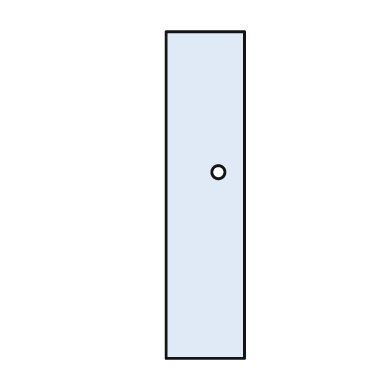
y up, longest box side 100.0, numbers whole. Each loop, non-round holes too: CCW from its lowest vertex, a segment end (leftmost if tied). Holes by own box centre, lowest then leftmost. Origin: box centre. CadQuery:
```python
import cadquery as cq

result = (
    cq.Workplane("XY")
    .moveTo(-12.0, -50.0)
    .lineTo(12.0, -50.0)
    .lineTo(12.0, 50.0)
    .lineTo(-12.0, 50.0)
    .close()
    .moveTo(4.0, 7.0)
    .circle(2.0)
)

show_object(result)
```